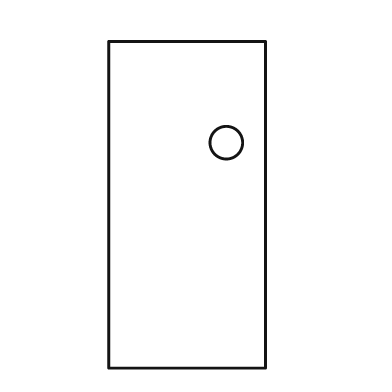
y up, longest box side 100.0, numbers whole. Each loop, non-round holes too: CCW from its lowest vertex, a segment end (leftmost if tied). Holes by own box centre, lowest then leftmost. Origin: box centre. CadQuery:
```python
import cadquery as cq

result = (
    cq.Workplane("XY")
    .moveTo(-24.0, -50.0)
    .lineTo(24.0, -50.0)
    .lineTo(24.0, 50.0)
    .lineTo(-24.0, 50.0)
    .close()
    .moveTo(12.0, 19.0)
    .circle(5.0)
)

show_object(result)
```